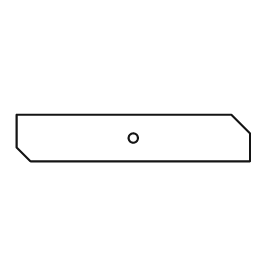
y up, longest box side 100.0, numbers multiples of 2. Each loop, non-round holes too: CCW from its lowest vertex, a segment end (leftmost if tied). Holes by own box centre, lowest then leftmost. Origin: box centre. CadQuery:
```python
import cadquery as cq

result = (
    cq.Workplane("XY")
    .moveTo(-44.0, -10.0)
    .lineTo(50.0, -10.0)
    .lineTo(50.0, 2.0)
    .lineTo(42.0, 10.0)
    .lineTo(-50.0, 10.0)
    .lineTo(-50.0, -4.0)
    .close()
    .moveTo(0.0, 0.0)
    .circle(2.0)
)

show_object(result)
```